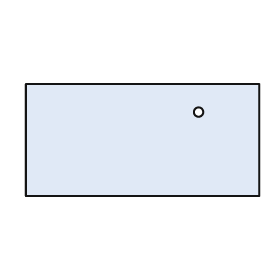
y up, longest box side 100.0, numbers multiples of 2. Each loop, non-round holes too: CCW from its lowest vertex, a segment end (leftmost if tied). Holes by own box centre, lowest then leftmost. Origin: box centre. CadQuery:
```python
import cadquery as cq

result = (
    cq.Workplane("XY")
    .moveTo(-50.0, -24.0)
    .lineTo(50.0, -24.0)
    .lineTo(50.0, 24.0)
    .lineTo(-50.0, 24.0)
    .close()
    .moveTo(24.0, 12.0)
    .circle(2.0)
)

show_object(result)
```